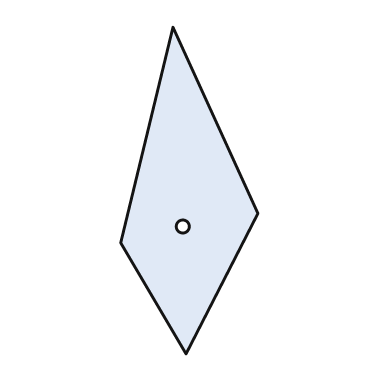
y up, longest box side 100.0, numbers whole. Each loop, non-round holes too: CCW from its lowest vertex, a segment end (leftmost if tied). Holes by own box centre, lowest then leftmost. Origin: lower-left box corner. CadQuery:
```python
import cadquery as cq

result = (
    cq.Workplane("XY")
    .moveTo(20.0, 0.0)
    .lineTo(42.0, 43.0)
    .lineTo(16.0, 100.0)
    .lineTo(0.0, 34.0)
    .close()
    .moveTo(19.0, 39.0)
    .circle(2.0)
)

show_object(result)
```